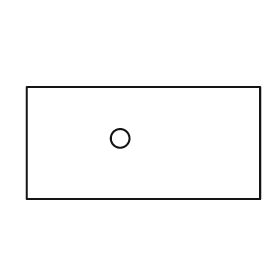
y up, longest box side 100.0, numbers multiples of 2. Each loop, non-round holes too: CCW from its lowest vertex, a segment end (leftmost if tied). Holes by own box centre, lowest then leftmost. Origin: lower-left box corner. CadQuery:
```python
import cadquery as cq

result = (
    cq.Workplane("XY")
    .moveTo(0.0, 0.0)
    .lineTo(100.0, 0.0)
    .lineTo(100.0, 48.0)
    .lineTo(0.0, 48.0)
    .close()
    .moveTo(40.0, 26.0)
    .circle(4.0)
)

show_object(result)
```